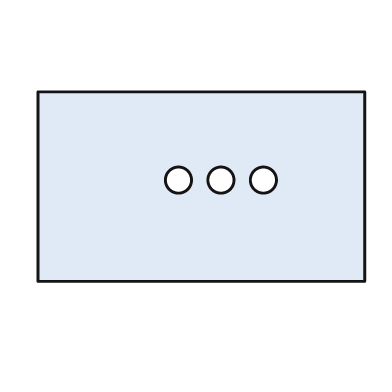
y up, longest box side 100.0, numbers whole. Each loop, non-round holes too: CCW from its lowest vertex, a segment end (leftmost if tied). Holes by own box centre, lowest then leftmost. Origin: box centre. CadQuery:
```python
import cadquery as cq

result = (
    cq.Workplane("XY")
    .moveTo(-50.0, -29.0)
    .lineTo(50.0, -29.0)
    .lineTo(50.0, 29.0)
    .lineTo(-50.0, 29.0)
    .close()
    .moveTo(-7.0, 2.0)
    .circle(4.0)
    .moveTo(6.0, 2.0)
    .circle(4.0)
    .moveTo(19.0, 2.0)
    .circle(4.0)
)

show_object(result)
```